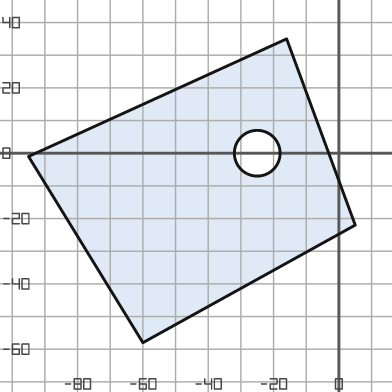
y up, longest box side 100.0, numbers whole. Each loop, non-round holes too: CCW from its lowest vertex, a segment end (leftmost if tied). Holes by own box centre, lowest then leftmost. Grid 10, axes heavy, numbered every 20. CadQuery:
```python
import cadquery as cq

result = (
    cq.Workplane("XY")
    .moveTo(-60.0, -58.0)
    .lineTo(5.0, -22.0)
    .lineTo(-16.0, 35.0)
    .lineTo(-95.0, -1.0)
    .close()
    .moveTo(-25.0, 0.0)
    .circle(7.0)
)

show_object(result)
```